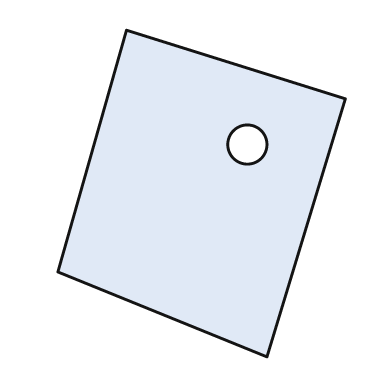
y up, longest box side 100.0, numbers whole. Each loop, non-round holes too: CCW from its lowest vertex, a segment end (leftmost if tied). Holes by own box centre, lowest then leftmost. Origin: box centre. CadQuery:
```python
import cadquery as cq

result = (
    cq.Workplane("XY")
    .moveTo(20.0, -50.0)
    .lineTo(44.0, 29.0)
    .lineTo(-23.0, 50.0)
    .lineTo(-44.0, -24.0)
    .close()
    .moveTo(14.0, 15.0)
    .circle(6.0)
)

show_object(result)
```